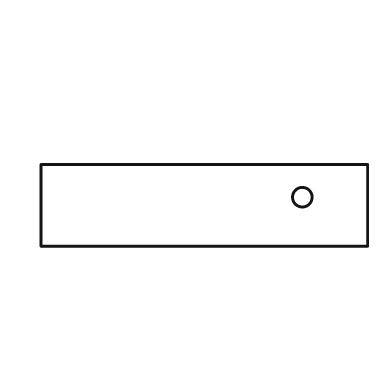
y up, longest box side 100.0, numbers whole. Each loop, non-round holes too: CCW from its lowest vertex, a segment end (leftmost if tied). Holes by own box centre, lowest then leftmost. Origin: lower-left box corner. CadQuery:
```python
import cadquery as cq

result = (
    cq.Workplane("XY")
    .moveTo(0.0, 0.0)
    .lineTo(100.0, 0.0)
    .lineTo(100.0, 25.0)
    .lineTo(0.0, 25.0)
    .close()
    .moveTo(80.0, 15.0)
    .circle(3.0)
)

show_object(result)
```